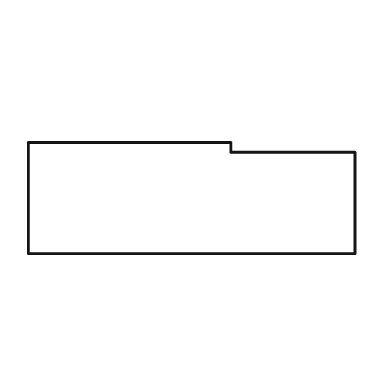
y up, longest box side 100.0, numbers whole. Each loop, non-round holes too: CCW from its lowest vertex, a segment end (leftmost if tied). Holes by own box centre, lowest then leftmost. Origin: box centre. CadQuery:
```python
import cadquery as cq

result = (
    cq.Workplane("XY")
    .moveTo(-50.0, -17.0)
    .lineTo(50.0, -17.0)
    .lineTo(50.0, 14.0)
    .lineTo(12.0, 14.0)
    .lineTo(12.0, 17.0)
    .lineTo(-50.0, 17.0)
    .close()
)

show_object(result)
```